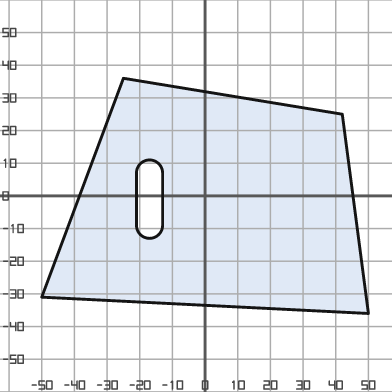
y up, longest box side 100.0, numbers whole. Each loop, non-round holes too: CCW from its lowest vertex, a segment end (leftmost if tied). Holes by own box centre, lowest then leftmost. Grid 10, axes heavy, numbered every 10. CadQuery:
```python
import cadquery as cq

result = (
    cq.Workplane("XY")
    .moveTo(50.0, -36.0)
    .lineTo(42.0, 25.0)
    .lineTo(-25.0, 36.0)
    .lineTo(-50.0, -31.0)
    .close()
    .moveTo(-21.0, -9.0)
    .threePointArc((-17.0, -13.0), (-13.0, -9.0))
    .lineTo(-13.0, 7.0)
    .threePointArc((-17.0, 11.0), (-21.0, 7.0))
    .close()
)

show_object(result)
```